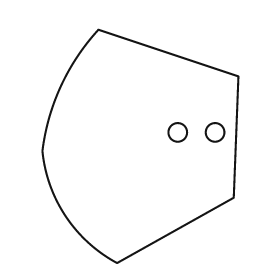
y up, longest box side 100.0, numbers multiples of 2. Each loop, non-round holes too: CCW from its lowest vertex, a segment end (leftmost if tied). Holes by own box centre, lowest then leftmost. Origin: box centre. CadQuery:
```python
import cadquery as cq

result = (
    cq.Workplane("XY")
    .moveTo(-10.0, -50.0)
    .lineTo(40.0, -22.0)
    .lineTo(42.0, 30.0)
    .lineTo(-18.0, 50.0)
    .threePointArc((-34.0, 26.0), (-42.0, -2.0))
    .threePointArc((-32.0, -30.0), (-10.0, -50.0))
    .close()
    .moveTo(16.0, 6.0)
    .circle(4.0)
    .moveTo(32.0, 6.0)
    .circle(4.0)
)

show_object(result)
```